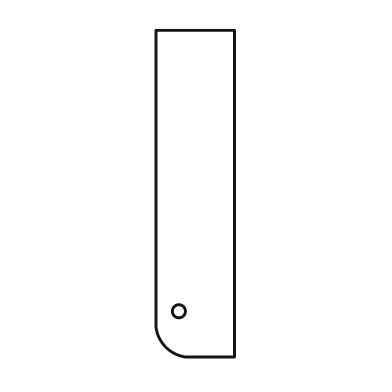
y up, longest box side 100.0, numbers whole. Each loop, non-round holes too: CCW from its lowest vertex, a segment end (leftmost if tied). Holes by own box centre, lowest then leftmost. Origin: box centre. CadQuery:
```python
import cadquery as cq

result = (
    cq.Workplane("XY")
    .moveTo(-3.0, -50.0)
    .lineTo(12.0, -50.0)
    .lineTo(12.0, 50.0)
    .lineTo(-12.0, 50.0)
    .lineTo(-12.0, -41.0)
    .threePointArc((-9.0, -47.0), (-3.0, -50.0))
    .close()
    .moveTo(-5.0, -36.0)
    .circle(2.0)
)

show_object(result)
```